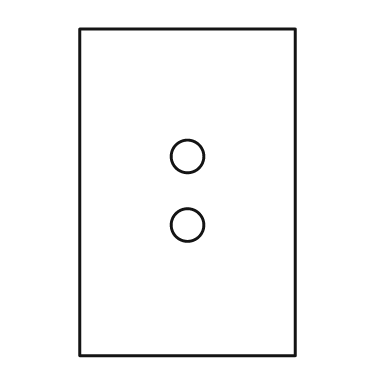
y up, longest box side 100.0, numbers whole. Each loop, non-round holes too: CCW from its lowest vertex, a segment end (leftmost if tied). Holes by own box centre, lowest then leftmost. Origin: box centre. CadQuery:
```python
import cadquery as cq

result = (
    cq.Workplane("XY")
    .moveTo(-33.0, -50.0)
    .lineTo(33.0, -50.0)
    .lineTo(33.0, 50.0)
    .lineTo(-33.0, 50.0)
    .close()
    .moveTo(0.0, -10.0)
    .circle(5.0)
    .moveTo(0.0, 11.0)
    .circle(5.0)
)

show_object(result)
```